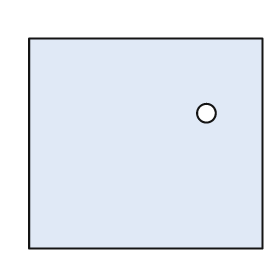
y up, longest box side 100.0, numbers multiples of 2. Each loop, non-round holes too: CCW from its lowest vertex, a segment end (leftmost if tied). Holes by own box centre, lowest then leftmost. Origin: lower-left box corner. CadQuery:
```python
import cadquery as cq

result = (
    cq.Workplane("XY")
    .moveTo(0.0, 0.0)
    .lineTo(100.0, 0.0)
    .lineTo(100.0, 90.0)
    .lineTo(0.0, 90.0)
    .close()
    .moveTo(76.0, 58.0)
    .circle(4.0)
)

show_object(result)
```